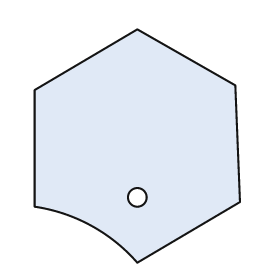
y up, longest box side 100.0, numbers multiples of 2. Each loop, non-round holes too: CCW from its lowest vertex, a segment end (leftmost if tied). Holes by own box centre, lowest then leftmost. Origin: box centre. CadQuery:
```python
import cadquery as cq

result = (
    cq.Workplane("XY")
    .moveTo(0.0, -50.0)
    .lineTo(44.0, -24.0)
    .lineTo(42.0, 26.0)
    .lineTo(0.0, 50.0)
    .lineTo(-44.0, 24.0)
    .lineTo(-44.0, -26.0)
    .threePointArc((-20.0, -34.0), (0.0, -50.0))
    .close()
    .moveTo(0.0, -22.0)
    .circle(4.0)
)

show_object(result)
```